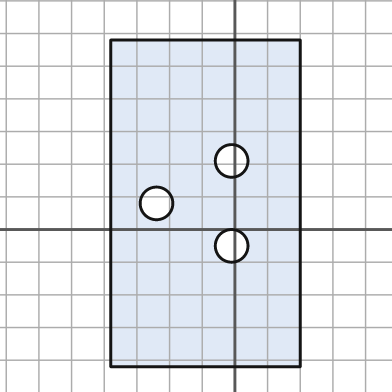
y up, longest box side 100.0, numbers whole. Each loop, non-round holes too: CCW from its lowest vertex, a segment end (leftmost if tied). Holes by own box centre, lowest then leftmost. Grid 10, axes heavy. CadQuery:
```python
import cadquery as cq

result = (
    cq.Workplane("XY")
    .moveTo(-38.0, -42.0)
    .lineTo(20.0, -42.0)
    .lineTo(20.0, 58.0)
    .lineTo(-38.0, 58.0)
    .close()
    .moveTo(-1.0, -5.0)
    .circle(5.0)
    .moveTo(-24.0, 8.0)
    .circle(5.0)
    .moveTo(-1.0, 21.0)
    .circle(5.0)
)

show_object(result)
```